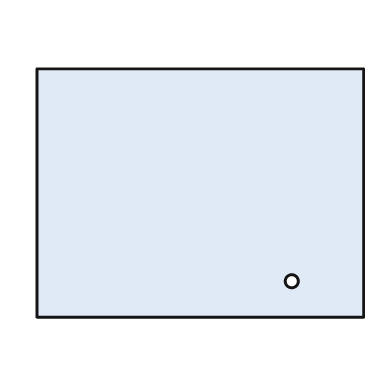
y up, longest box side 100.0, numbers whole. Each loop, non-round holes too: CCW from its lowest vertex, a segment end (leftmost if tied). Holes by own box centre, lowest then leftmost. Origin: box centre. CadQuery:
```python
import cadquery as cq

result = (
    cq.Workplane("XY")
    .moveTo(-50.0, -38.0)
    .lineTo(50.0, -38.0)
    .lineTo(50.0, 38.0)
    .lineTo(-50.0, 38.0)
    .close()
    .moveTo(28.0, -27.0)
    .circle(2.0)
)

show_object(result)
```